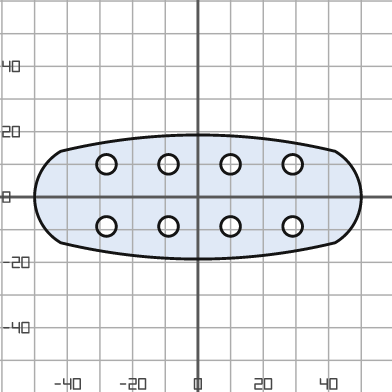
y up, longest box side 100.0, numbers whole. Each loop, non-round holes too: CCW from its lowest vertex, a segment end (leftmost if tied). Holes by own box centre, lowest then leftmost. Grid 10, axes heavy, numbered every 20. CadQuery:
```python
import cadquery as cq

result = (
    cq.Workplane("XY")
    .moveTo(-42.0, -14.0)
    .threePointArc((0.0, -19.0), (42.0, -14.0))
    .threePointArc((50.0, 0.0), (42.0, 14.0))
    .threePointArc((0.0, 19.0), (-42.0, 14.0))
    .threePointArc((-50.0, 0.0), (-42.0, -14.0))
    .close()
    .moveTo(-28.0, -9.0)
    .circle(3.0)
    .moveTo(-9.0, -9.0)
    .circle(3.0)
    .moveTo(10.0, -9.0)
    .circle(3.0)
    .moveTo(29.0, -9.0)
    .circle(3.0)
    .moveTo(-28.0, 10.0)
    .circle(3.0)
    .moveTo(-9.0, 10.0)
    .circle(3.0)
    .moveTo(10.0, 10.0)
    .circle(3.0)
    .moveTo(29.0, 10.0)
    .circle(3.0)
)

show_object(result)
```